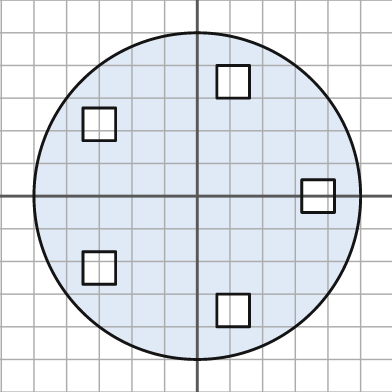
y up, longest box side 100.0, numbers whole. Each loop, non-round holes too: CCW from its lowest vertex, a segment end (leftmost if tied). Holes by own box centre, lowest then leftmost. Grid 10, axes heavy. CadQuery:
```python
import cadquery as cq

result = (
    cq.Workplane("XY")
    .moveTo(0.0, 0.0)
    .circle(50.0)
    .moveTo(6.0, -40.0)
    .lineTo(16.0, -40.0)
    .lineTo(16.0, -30.0)
    .lineTo(6.0, -30.0)
    .close()
    .moveTo(-35.0, -27.0)
    .lineTo(-25.0, -27.0)
    .lineTo(-25.0, -17.0)
    .lineTo(-35.0, -17.0)
    .close()
    .moveTo(32.0, -5.0)
    .lineTo(42.0, -5.0)
    .lineTo(42.0, 5.0)
    .lineTo(32.0, 5.0)
    .close()
    .moveTo(-35.0, 17.0)
    .lineTo(-25.0, 17.0)
    .lineTo(-25.0, 27.0)
    .lineTo(-35.0, 27.0)
    .close()
    .moveTo(6.0, 30.0)
    .lineTo(16.0, 30.0)
    .lineTo(16.0, 40.0)
    .lineTo(6.0, 40.0)
    .close()
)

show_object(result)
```